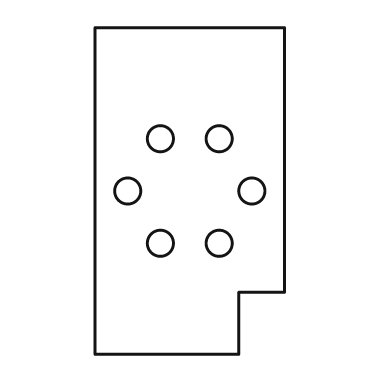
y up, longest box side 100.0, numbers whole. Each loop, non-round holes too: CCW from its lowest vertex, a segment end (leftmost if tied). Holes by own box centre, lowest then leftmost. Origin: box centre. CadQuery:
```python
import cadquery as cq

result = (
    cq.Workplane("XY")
    .moveTo(-29.0, -50.0)
    .lineTo(15.0, -50.0)
    .lineTo(15.0, -31.0)
    .lineTo(29.0, -31.0)
    .lineTo(29.0, 50.0)
    .lineTo(-29.0, 50.0)
    .close()
    .moveTo(-9.0, -16.0)
    .circle(4.0)
    .moveTo(9.0, -16.0)
    .circle(4.0)
    .moveTo(-19.0, 0.0)
    .circle(4.0)
    .moveTo(19.0, 0.0)
    .circle(4.0)
    .moveTo(-9.0, 16.0)
    .circle(4.0)
    .moveTo(9.0, 16.0)
    .circle(4.0)
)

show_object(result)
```